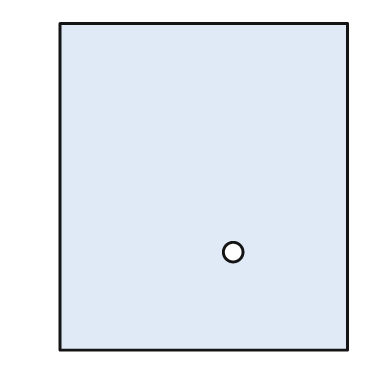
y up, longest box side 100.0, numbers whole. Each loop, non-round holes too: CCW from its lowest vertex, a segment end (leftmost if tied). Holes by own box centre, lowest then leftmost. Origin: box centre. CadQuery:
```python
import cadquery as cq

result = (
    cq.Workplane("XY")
    .moveTo(-44.0, -50.0)
    .lineTo(44.0, -50.0)
    .lineTo(44.0, 50.0)
    .lineTo(-44.0, 50.0)
    .close()
    .moveTo(9.0, -20.0)
    .circle(3.0)
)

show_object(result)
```